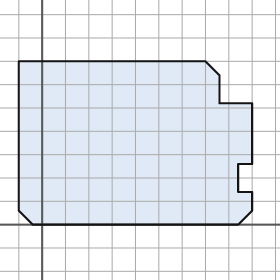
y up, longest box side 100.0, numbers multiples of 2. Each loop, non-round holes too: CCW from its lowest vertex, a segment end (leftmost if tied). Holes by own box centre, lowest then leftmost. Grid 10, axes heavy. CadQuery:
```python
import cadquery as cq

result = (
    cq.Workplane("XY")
    .moveTo(-4.0, 0.0)
    .lineTo(84.0, 0.0)
    .lineTo(90.0, 6.0)
    .lineTo(90.0, 14.0)
    .lineTo(84.0, 14.0)
    .lineTo(84.0, 26.0)
    .lineTo(90.0, 26.0)
    .lineTo(90.0, 52.0)
    .lineTo(76.0, 52.0)
    .lineTo(76.0, 64.0)
    .lineTo(70.0, 70.0)
    .lineTo(-10.0, 70.0)
    .lineTo(-10.0, 6.0)
    .close()
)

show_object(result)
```